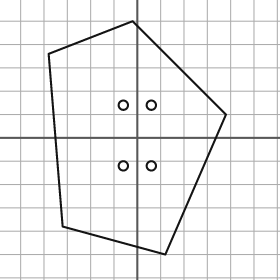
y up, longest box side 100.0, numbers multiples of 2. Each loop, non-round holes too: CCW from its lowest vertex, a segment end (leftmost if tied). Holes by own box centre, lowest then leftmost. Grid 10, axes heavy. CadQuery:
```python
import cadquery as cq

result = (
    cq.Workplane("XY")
    .moveTo(12.0, -50.0)
    .lineTo(38.0, 10.0)
    .lineTo(-2.0, 50.0)
    .lineTo(-38.0, 36.0)
    .lineTo(-32.0, -38.0)
    .close()
    .moveTo(-6.0, -12.0)
    .circle(2.0)
    .moveTo(6.0, -12.0)
    .circle(2.0)
    .moveTo(-6.0, 14.0)
    .circle(2.0)
    .moveTo(6.0, 14.0)
    .circle(2.0)
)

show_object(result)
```